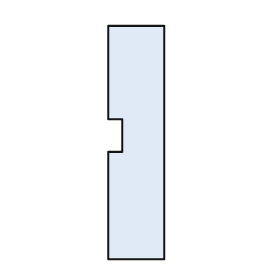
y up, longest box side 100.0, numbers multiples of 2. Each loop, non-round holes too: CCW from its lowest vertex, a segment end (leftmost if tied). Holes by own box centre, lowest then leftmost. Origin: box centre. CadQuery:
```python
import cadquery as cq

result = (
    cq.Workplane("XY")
    .moveTo(-12.0, -50.0)
    .lineTo(12.0, -50.0)
    .lineTo(12.0, 50.0)
    .lineTo(-12.0, 50.0)
    .lineTo(-12.0, 10.0)
    .lineTo(-6.0, 10.0)
    .lineTo(-6.0, -4.0)
    .lineTo(-12.0, -4.0)
    .close()
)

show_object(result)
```